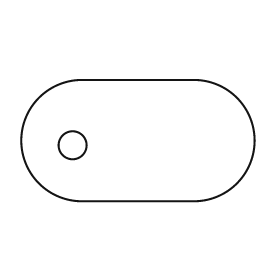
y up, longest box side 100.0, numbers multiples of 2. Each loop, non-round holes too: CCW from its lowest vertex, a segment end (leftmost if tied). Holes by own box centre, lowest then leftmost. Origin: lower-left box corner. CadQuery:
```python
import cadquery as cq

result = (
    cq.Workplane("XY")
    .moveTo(26.0, 0.0)
    .lineTo(74.0, 0.0)
    .threePointArc((100.0, 26.0), (74.0, 52.0))
    .lineTo(26.0, 52.0)
    .threePointArc((0.0, 26.0), (26.0, 0.0))
    .close()
    .moveTo(22.0, 24.0)
    .circle(6.0)
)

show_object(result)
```